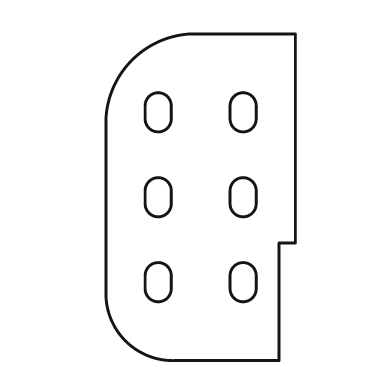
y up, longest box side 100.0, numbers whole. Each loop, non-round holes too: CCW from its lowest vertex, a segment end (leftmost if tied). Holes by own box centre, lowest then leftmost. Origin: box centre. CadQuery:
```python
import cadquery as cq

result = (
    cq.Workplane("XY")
    .moveTo(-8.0, -50.0)
    .lineTo(24.0, -50.0)
    .lineTo(24.0, -14.0)
    .lineTo(29.0, -14.0)
    .lineTo(29.0, 50.0)
    .lineTo(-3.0, 50.0)
    .threePointArc((-21.0, 42.0), (-29.0, 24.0))
    .lineTo(-29.0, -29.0)
    .threePointArc((-23.0, -44.0), (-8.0, -50.0))
    .close()
    .moveTo(-17.0, -28.0)
    .threePointArc((-13.0, -32.0), (-9.0, -28.0))
    .lineTo(-9.0, -24.0)
    .threePointArc((-13.0, -20.0), (-17.0, -24.0))
    .close()
    .moveTo(9.0, -28.0)
    .threePointArc((13.0, -32.0), (17.0, -28.0))
    .lineTo(17.0, -24.0)
    .threePointArc((13.0, -20.0), (9.0, -24.0))
    .close()
    .moveTo(-17.0, -2.0)
    .threePointArc((-13.0, -6.0), (-9.0, -2.0))
    .lineTo(-9.0, 2.0)
    .threePointArc((-13.0, 6.0), (-17.0, 2.0))
    .close()
    .moveTo(9.0, -2.0)
    .threePointArc((13.0, -6.0), (17.0, -2.0))
    .lineTo(17.0, 2.0)
    .threePointArc((13.0, 6.0), (9.0, 2.0))
    .close()
    .moveTo(-17.0, 24.0)
    .threePointArc((-13.0, 20.0), (-9.0, 24.0))
    .lineTo(-9.0, 28.0)
    .threePointArc((-13.0, 32.0), (-17.0, 28.0))
    .close()
    .moveTo(9.0, 24.0)
    .threePointArc((13.0, 20.0), (17.0, 24.0))
    .lineTo(17.0, 28.0)
    .threePointArc((13.0, 32.0), (9.0, 28.0))
    .close()
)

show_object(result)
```